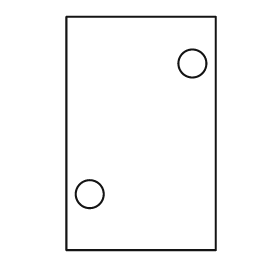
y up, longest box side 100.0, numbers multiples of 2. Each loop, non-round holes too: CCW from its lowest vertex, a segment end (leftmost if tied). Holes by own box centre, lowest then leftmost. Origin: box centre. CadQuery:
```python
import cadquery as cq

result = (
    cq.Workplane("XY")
    .moveTo(-32.0, -50.0)
    .lineTo(32.0, -50.0)
    .lineTo(32.0, 50.0)
    .lineTo(-32.0, 50.0)
    .close()
    .moveTo(-22.0, -26.0)
    .circle(6.0)
    .moveTo(22.0, 30.0)
    .circle(6.0)
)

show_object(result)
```